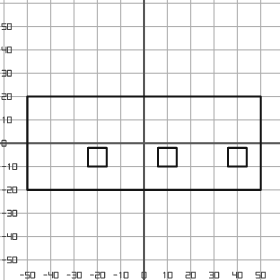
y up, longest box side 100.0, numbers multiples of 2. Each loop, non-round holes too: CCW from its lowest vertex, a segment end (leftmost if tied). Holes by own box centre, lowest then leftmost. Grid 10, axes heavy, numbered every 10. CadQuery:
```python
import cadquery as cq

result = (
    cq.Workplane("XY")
    .moveTo(-50.0, -20.0)
    .lineTo(50.0, -20.0)
    .lineTo(50.0, 20.0)
    .lineTo(-50.0, 20.0)
    .close()
    .moveTo(-24.0, -10.0)
    .lineTo(-16.0, -10.0)
    .lineTo(-16.0, -2.0)
    .lineTo(-24.0, -2.0)
    .close()
    .moveTo(6.0, -10.0)
    .lineTo(14.0, -10.0)
    .lineTo(14.0, -2.0)
    .lineTo(6.0, -2.0)
    .close()
    .moveTo(36.0, -10.0)
    .lineTo(44.0, -10.0)
    .lineTo(44.0, -2.0)
    .lineTo(36.0, -2.0)
    .close()
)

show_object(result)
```